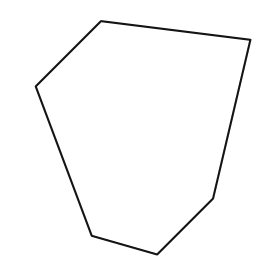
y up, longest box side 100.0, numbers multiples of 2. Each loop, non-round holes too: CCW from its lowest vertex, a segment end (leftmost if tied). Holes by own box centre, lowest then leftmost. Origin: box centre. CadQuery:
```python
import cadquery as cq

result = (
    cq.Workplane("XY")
    .moveTo(6.0, -50.0)
    .lineTo(30.0, -26.0)
    .lineTo(46.0, 42.0)
    .lineTo(-18.0, 50.0)
    .lineTo(-46.0, 22.0)
    .lineTo(-22.0, -42.0)
    .close()
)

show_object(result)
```